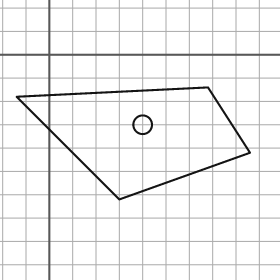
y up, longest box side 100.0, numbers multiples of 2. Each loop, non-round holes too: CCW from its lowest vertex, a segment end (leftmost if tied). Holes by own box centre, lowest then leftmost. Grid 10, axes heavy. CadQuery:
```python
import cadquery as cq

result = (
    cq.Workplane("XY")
    .moveTo(30.0, -62.0)
    .lineTo(86.0, -42.0)
    .lineTo(68.0, -14.0)
    .lineTo(-14.0, -18.0)
    .close()
    .moveTo(40.0, -30.0)
    .circle(4.0)
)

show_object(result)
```